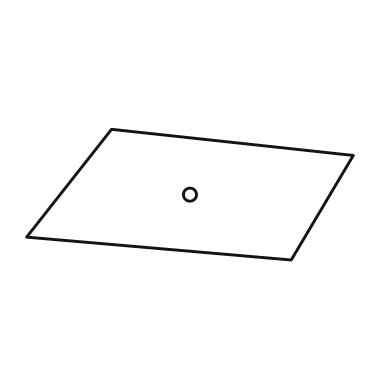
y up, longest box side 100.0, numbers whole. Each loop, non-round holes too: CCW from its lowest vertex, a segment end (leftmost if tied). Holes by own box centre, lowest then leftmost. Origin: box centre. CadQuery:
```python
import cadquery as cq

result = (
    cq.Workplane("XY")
    .moveTo(31.0, -20.0)
    .lineTo(50.0, 12.0)
    .lineTo(-24.0, 20.0)
    .lineTo(-50.0, -13.0)
    .close()
    .moveTo(0.0, 0.0)
    .circle(2.0)
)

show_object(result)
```